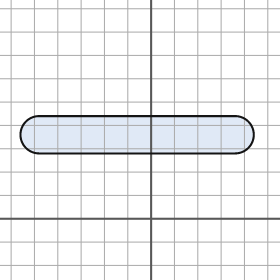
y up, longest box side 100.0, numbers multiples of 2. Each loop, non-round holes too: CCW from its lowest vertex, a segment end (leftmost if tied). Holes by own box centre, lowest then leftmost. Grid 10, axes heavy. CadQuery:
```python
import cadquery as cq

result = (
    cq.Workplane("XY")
    .moveTo(-48.0, 28.0)
    .lineTo(36.0, 28.0)
    .threePointArc((44.0, 36.0), (36.0, 44.0))
    .lineTo(-48.0, 44.0)
    .threePointArc((-56.0, 36.0), (-48.0, 28.0))
    .close()
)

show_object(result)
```